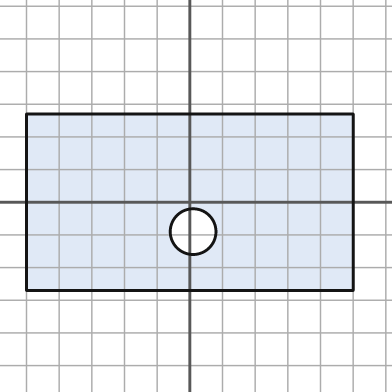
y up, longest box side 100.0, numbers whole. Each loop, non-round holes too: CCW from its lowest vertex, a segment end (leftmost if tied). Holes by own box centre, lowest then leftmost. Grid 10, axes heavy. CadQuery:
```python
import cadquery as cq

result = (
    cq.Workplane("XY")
    .moveTo(-50.0, -27.0)
    .lineTo(50.0, -27.0)
    .lineTo(50.0, 27.0)
    .lineTo(-50.0, 27.0)
    .close()
    .moveTo(1.0, -9.0)
    .circle(7.0)
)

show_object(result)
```